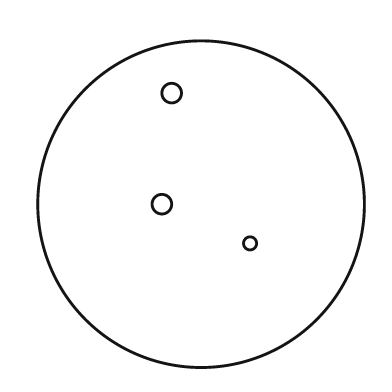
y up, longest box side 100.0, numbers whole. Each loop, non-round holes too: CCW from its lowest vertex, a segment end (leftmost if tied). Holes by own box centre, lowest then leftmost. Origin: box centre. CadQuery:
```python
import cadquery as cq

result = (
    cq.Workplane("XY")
    .moveTo(0.0, 0.0)
    .circle(50.0)
    .moveTo(15.0, -12.0)
    .circle(2.0)
    .moveTo(-12.0, 0.0)
    .circle(3.0)
    .moveTo(-9.0, 34.0)
    .circle(3.0)
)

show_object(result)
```